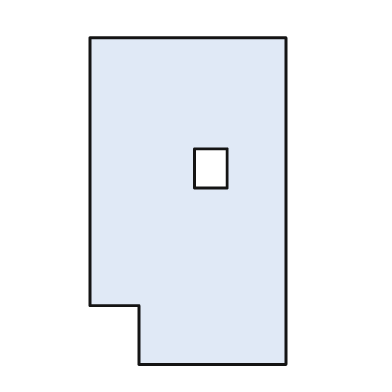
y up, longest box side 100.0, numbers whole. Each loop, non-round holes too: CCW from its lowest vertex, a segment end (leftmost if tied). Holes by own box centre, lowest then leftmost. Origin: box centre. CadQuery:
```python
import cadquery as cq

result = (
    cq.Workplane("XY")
    .moveTo(-15.0, -50.0)
    .lineTo(30.0, -50.0)
    .lineTo(30.0, 50.0)
    .lineTo(-30.0, 50.0)
    .lineTo(-30.0, -32.0)
    .lineTo(-15.0, -32.0)
    .close()
    .moveTo(2.0, 4.0)
    .lineTo(12.0, 4.0)
    .lineTo(12.0, 16.0)
    .lineTo(2.0, 16.0)
    .close()
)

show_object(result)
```